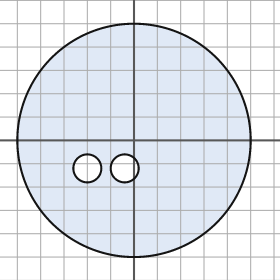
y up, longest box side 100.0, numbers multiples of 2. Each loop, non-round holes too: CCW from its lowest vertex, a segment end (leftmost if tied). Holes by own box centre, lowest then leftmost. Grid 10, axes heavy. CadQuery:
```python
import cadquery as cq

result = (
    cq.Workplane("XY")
    .moveTo(0.0, 0.0)
    .circle(50.0)
    .moveTo(-20.0, -12.0)
    .circle(6.0)
    .moveTo(-4.0, -12.0)
    .circle(6.0)
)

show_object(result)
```